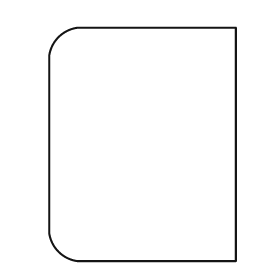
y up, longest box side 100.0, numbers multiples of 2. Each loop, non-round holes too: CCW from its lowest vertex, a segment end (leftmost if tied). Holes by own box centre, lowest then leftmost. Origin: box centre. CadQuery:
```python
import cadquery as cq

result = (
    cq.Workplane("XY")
    .moveTo(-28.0, -50.0)
    .lineTo(40.0, -50.0)
    .lineTo(40.0, 50.0)
    .lineTo(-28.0, 50.0)
    .threePointArc((-36.0, 46.0), (-40.0, 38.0))
    .lineTo(-40.0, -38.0)
    .threePointArc((-36.0, -46.0), (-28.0, -50.0))
    .close()
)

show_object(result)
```